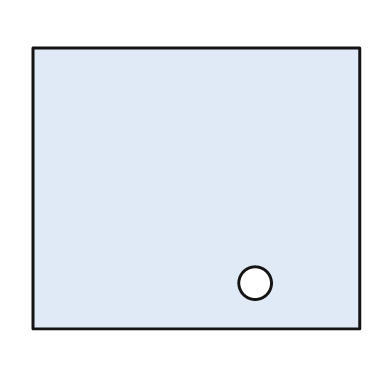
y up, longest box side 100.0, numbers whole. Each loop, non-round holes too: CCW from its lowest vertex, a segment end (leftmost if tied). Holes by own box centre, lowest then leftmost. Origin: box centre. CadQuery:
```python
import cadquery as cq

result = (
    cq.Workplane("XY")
    .moveTo(-50.0, -43.0)
    .lineTo(50.0, -43.0)
    .lineTo(50.0, 43.0)
    .lineTo(-50.0, 43.0)
    .close()
    .moveTo(18.0, -29.0)
    .circle(5.0)
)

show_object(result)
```